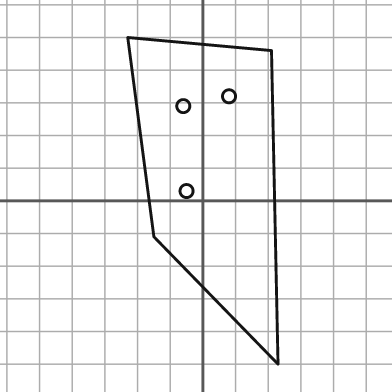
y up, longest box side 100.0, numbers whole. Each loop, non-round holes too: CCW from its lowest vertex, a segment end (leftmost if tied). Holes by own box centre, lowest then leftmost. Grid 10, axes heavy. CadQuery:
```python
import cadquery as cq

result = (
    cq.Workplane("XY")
    .moveTo(23.0, -50.0)
    .lineTo(21.0, 46.0)
    .lineTo(-23.0, 50.0)
    .lineTo(-15.0, -11.0)
    .close()
    .moveTo(-5.0, 3.0)
    .circle(2.0)
    .moveTo(-6.0, 29.0)
    .circle(2.0)
    .moveTo(8.0, 32.0)
    .circle(2.0)
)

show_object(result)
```